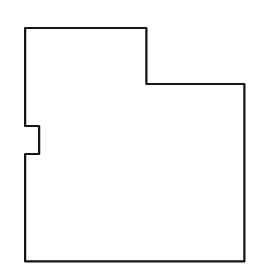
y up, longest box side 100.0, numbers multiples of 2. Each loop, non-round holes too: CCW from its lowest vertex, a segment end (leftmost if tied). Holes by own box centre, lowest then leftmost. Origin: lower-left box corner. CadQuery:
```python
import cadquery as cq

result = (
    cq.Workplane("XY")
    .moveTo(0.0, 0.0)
    .lineTo(94.0, 0.0)
    .lineTo(94.0, 76.0)
    .lineTo(52.0, 76.0)
    .lineTo(52.0, 100.0)
    .lineTo(0.0, 100.0)
    .lineTo(0.0, 58.0)
    .lineTo(6.0, 58.0)
    .lineTo(6.0, 46.0)
    .lineTo(0.0, 46.0)
    .close()
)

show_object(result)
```